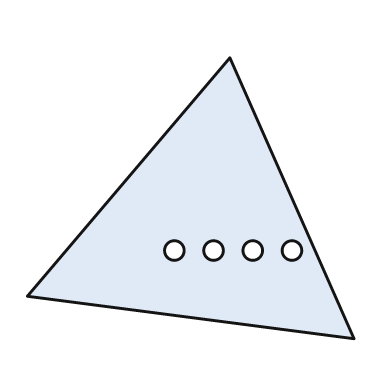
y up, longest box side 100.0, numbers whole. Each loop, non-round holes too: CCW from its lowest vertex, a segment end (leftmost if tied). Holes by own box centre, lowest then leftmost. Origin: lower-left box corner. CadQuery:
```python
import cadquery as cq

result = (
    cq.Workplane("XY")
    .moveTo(100.0, 0.0)
    .lineTo(62.0, 86.0)
    .lineTo(0.0, 13.0)
    .close()
    .moveTo(45.0, 27.0)
    .circle(3.0)
    .moveTo(57.0, 27.0)
    .circle(3.0)
    .moveTo(69.0, 27.0)
    .circle(3.0)
    .moveTo(81.0, 27.0)
    .circle(3.0)
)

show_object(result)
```